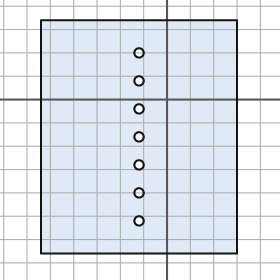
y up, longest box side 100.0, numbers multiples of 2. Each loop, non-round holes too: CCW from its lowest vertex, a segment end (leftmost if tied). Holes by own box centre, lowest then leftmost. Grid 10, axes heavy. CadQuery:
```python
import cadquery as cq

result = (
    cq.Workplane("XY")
    .moveTo(-54.0, -66.0)
    .lineTo(30.0, -66.0)
    .lineTo(30.0, 34.0)
    .lineTo(-54.0, 34.0)
    .close()
    .moveTo(-12.0, -52.0)
    .circle(2.0)
    .moveTo(-12.0, -40.0)
    .circle(2.0)
    .moveTo(-12.0, -28.0)
    .circle(2.0)
    .moveTo(-12.0, -16.0)
    .circle(2.0)
    .moveTo(-12.0, -4.0)
    .circle(2.0)
    .moveTo(-12.0, 8.0)
    .circle(2.0)
    .moveTo(-12.0, 20.0)
    .circle(2.0)
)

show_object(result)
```